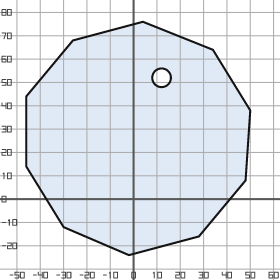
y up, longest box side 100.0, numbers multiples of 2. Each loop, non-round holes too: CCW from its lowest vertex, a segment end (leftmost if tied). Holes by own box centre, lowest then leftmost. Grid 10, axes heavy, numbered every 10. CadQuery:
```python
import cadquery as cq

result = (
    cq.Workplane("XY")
    .moveTo(-2.0, -24.0)
    .lineTo(28.0, -16.0)
    .lineTo(48.0, 8.0)
    .lineTo(50.0, 38.0)
    .lineTo(34.0, 64.0)
    .lineTo(4.0, 76.0)
    .lineTo(-26.0, 68.0)
    .lineTo(-46.0, 44.0)
    .lineTo(-46.0, 14.0)
    .lineTo(-30.0, -12.0)
    .close()
    .moveTo(12.0, 52.0)
    .circle(4.0)
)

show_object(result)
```